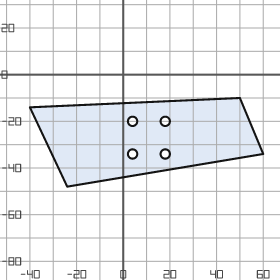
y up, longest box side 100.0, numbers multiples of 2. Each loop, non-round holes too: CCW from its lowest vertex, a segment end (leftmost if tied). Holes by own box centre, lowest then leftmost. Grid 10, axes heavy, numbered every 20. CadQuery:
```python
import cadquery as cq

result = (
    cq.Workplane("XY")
    .moveTo(-24.0, -48.0)
    .lineTo(60.0, -34.0)
    .lineTo(50.0, -10.0)
    .lineTo(-40.0, -14.0)
    .close()
    .moveTo(4.0, -34.0)
    .circle(2.0)
    .moveTo(18.0, -34.0)
    .circle(2.0)
    .moveTo(4.0, -20.0)
    .circle(2.0)
    .moveTo(18.0, -20.0)
    .circle(2.0)
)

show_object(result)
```